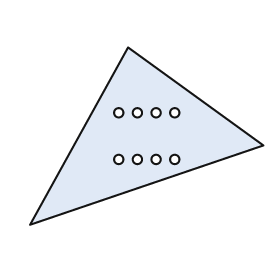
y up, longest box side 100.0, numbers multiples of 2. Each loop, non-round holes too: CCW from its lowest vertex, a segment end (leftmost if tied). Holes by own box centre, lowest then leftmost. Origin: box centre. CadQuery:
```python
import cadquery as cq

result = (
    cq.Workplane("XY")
    .moveTo(-50.0, -38.0)
    .lineTo(50.0, -4.0)
    .lineTo(-8.0, 38.0)
    .close()
    .moveTo(-12.0, -10.0)
    .circle(2.0)
    .moveTo(-4.0, -10.0)
    .circle(2.0)
    .moveTo(4.0, -10.0)
    .circle(2.0)
    .moveTo(12.0, -10.0)
    .circle(2.0)
    .moveTo(-12.0, 10.0)
    .circle(2.0)
    .moveTo(-4.0, 10.0)
    .circle(2.0)
    .moveTo(4.0, 10.0)
    .circle(2.0)
    .moveTo(12.0, 10.0)
    .circle(2.0)
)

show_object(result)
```